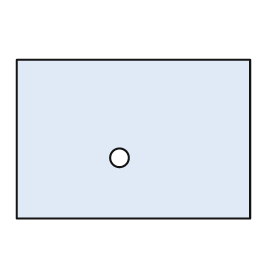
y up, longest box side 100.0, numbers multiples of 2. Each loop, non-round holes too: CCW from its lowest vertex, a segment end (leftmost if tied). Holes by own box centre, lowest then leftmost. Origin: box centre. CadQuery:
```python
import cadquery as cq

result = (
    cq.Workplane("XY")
    .moveTo(-50.0, -34.0)
    .lineTo(50.0, -34.0)
    .lineTo(50.0, 34.0)
    .lineTo(-50.0, 34.0)
    .close()
    .moveTo(-6.0, -8.0)
    .circle(4.0)
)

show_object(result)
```